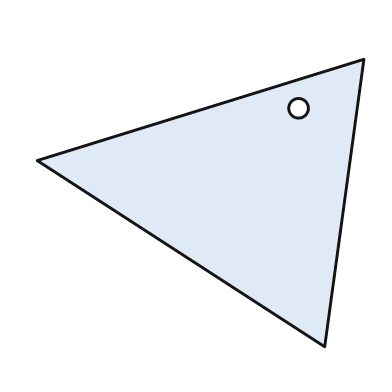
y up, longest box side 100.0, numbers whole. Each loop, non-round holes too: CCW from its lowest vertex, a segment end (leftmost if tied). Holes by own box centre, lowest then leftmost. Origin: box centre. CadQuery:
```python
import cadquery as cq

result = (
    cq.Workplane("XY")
    .moveTo(38.0, -44.0)
    .lineTo(50.0, 44.0)
    .lineTo(-50.0, 13.0)
    .close()
    .moveTo(30.0, 29.0)
    .circle(3.0)
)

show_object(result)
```